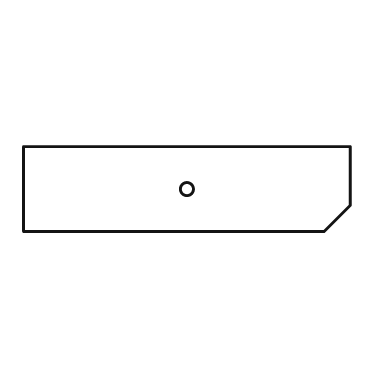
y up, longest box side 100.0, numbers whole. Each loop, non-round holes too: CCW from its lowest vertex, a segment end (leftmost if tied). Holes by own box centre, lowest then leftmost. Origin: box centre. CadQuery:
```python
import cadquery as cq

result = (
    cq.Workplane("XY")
    .moveTo(-50.0, -13.0)
    .lineTo(42.0, -13.0)
    .lineTo(50.0, -5.0)
    .lineTo(50.0, 13.0)
    .lineTo(-50.0, 13.0)
    .close()
    .moveTo(0.0, 0.0)
    .circle(2.0)
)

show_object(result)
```